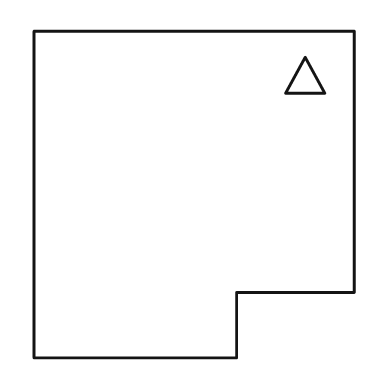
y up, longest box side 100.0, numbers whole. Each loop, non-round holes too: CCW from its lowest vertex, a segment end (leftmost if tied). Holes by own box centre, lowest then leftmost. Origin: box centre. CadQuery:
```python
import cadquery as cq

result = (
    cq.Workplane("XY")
    .moveTo(-49.0, -50.0)
    .lineTo(13.0, -50.0)
    .lineTo(13.0, -30.0)
    .lineTo(49.0, -30.0)
    .lineTo(49.0, 50.0)
    .lineTo(-49.0, 50.0)
    .close()
    .moveTo(28.0, 31.0)
    .lineTo(40.0, 31.0)
    .lineTo(34.0, 42.0)
    .close()
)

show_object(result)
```